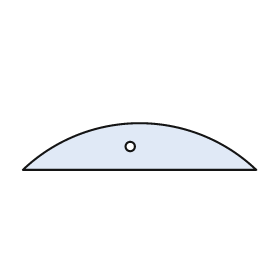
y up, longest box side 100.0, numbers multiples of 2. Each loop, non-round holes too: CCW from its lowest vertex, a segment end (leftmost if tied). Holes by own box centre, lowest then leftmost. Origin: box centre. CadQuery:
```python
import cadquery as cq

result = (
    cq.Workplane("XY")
    .moveTo(-50.0, -10.0)
    .lineTo(50.0, -10.0)
    .threePointArc((0.0, 10.0), (-50.0, -10.0))
    .close()
    .moveTo(-4.0, 0.0)
    .circle(2.0)
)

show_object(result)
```